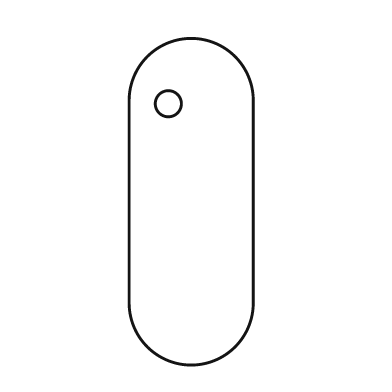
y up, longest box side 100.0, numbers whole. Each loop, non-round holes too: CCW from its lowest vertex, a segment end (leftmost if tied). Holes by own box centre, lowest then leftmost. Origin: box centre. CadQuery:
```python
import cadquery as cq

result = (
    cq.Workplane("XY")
    .moveTo(-19.0, -31.0)
    .threePointArc((0.0, -50.0), (19.0, -31.0))
    .lineTo(19.0, 31.0)
    .threePointArc((0.0, 50.0), (-19.0, 31.0))
    .close()
    .moveTo(-7.0, 30.0)
    .circle(4.0)
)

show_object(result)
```